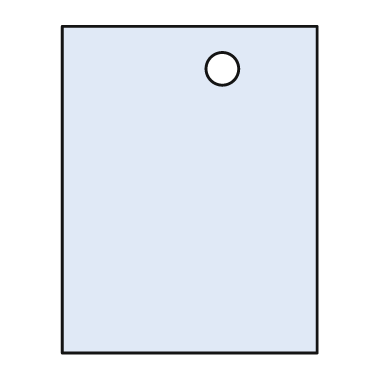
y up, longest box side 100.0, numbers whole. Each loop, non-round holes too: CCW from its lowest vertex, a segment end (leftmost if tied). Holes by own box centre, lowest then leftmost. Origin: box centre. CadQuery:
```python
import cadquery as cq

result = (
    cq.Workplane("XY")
    .moveTo(-39.0, -50.0)
    .lineTo(39.0, -50.0)
    .lineTo(39.0, 50.0)
    .lineTo(-39.0, 50.0)
    .close()
    .moveTo(10.0, 37.0)
    .circle(5.0)
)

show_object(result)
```